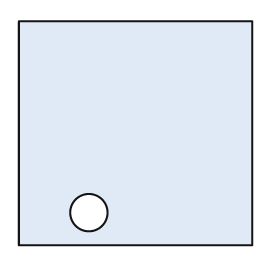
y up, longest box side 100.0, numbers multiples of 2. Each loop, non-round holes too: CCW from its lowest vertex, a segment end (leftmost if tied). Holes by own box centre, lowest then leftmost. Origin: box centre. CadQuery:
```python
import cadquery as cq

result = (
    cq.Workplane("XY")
    .moveTo(-50.0, -48.0)
    .lineTo(50.0, -48.0)
    .lineTo(50.0, 48.0)
    .lineTo(-50.0, 48.0)
    .close()
    .moveTo(-20.0, -34.0)
    .circle(8.0)
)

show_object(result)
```